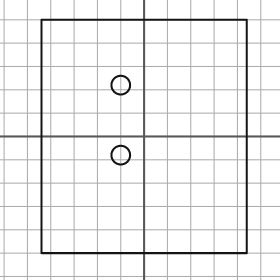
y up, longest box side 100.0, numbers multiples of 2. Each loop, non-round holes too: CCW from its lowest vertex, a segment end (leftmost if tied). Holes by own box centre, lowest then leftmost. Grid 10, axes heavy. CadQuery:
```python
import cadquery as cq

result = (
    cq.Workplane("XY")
    .moveTo(-44.0, -50.0)
    .lineTo(44.0, -50.0)
    .lineTo(44.0, 50.0)
    .lineTo(-44.0, 50.0)
    .close()
    .moveTo(-10.0, -8.0)
    .circle(4.0)
    .moveTo(-10.0, 22.0)
    .circle(4.0)
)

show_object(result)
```